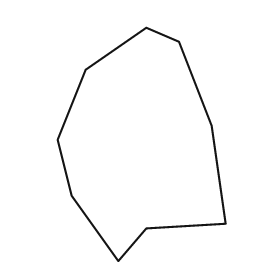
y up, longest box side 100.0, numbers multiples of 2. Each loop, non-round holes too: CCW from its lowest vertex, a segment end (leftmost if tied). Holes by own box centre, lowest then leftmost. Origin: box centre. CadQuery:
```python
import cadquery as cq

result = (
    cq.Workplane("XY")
    .moveTo(-10.0, -50.0)
    .lineTo(2.0, -36.0)
    .lineTo(36.0, -34.0)
    .lineTo(30.0, 8.0)
    .lineTo(16.0, 44.0)
    .lineTo(2.0, 50.0)
    .lineTo(-24.0, 32.0)
    .lineTo(-36.0, 2.0)
    .lineTo(-30.0, -22.0)
    .close()
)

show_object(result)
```